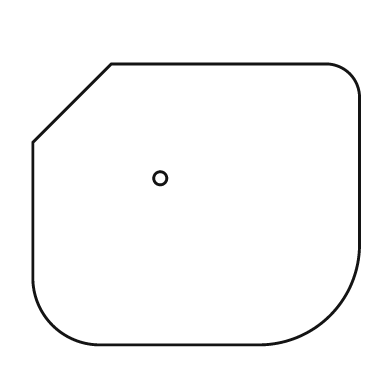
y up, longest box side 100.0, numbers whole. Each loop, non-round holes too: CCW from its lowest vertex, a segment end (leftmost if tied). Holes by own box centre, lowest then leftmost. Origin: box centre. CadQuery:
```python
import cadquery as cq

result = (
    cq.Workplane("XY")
    .moveTo(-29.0, -43.0)
    .lineTo(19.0, -43.0)
    .threePointArc((41.0, -34.0), (50.0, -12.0))
    .lineTo(50.0, 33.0)
    .threePointArc((47.0, 40.0), (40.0, 43.0))
    .lineTo(-26.0, 43.0)
    .lineTo(-50.0, 19.0)
    .lineTo(-50.0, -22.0)
    .threePointArc((-44.0, -37.0), (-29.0, -43.0))
    .close()
    .moveTo(-11.0, 8.0)
    .circle(2.0)
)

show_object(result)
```